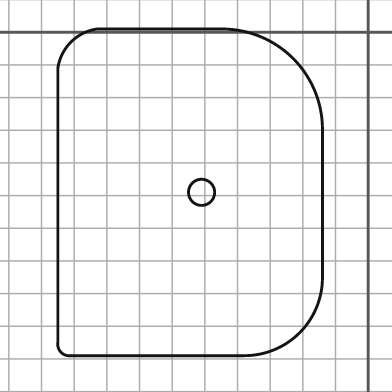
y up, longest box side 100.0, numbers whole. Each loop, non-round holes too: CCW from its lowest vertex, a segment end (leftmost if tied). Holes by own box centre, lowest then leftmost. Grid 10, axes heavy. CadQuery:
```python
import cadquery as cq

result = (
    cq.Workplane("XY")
    .moveTo(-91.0, -99.0)
    .lineTo(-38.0, -99.0)
    .threePointArc((-21.0, -92.0), (-14.0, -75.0))
    .lineTo(-14.0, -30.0)
    .threePointArc((-23.0, -8.0), (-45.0, 1.0))
    .lineTo(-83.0, 1.0)
    .threePointArc((-91.0, -3.0), (-95.0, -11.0))
    .lineTo(-95.0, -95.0)
    .threePointArc((-94.0, -98.0), (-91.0, -99.0))
    .close()
    .moveTo(-51.0, -49.0)
    .circle(4.0)
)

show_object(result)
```